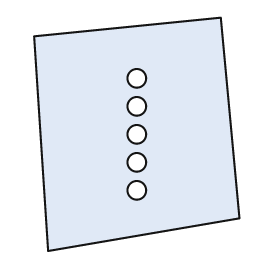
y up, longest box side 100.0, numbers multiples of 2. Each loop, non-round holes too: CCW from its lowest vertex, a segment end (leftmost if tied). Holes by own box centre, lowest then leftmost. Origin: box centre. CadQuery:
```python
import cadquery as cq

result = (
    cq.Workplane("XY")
    .moveTo(-38.0, -50.0)
    .lineTo(44.0, -36.0)
    .lineTo(36.0, 50.0)
    .lineTo(-44.0, 42.0)
    .close()
    .moveTo(0.0, -24.0)
    .circle(4.0)
    .moveTo(0.0, -12.0)
    .circle(4.0)
    .moveTo(0.0, 0.0)
    .circle(4.0)
    .moveTo(0.0, 12.0)
    .circle(4.0)
    .moveTo(0.0, 24.0)
    .circle(4.0)
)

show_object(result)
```